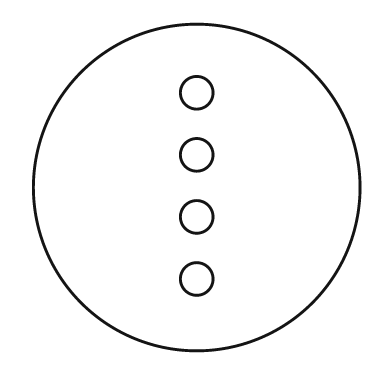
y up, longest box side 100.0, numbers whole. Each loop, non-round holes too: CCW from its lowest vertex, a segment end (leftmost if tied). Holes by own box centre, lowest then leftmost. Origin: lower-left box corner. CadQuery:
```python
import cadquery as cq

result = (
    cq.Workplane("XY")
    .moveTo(50.0, 50.0)
    .circle(50.0)
    .moveTo(50.0, 22.0)
    .circle(5.0)
    .moveTo(50.0, 41.0)
    .circle(5.0)
    .moveTo(50.0, 60.0)
    .circle(5.0)
    .moveTo(50.0, 79.0)
    .circle(5.0)
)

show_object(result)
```